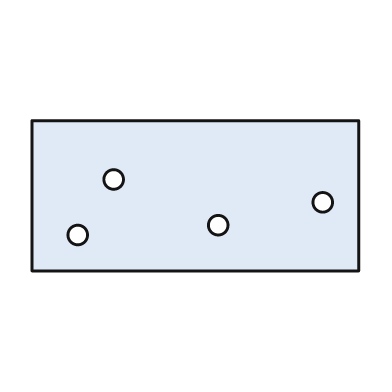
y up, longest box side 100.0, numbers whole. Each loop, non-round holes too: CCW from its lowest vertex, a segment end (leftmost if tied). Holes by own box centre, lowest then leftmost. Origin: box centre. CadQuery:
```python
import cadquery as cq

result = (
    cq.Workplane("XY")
    .moveTo(-50.0, -23.0)
    .lineTo(50.0, -23.0)
    .lineTo(50.0, 23.0)
    .lineTo(-50.0, 23.0)
    .close()
    .moveTo(-36.0, -12.0)
    .circle(3.0)
    .moveTo(7.0, -9.0)
    .circle(3.0)
    .moveTo(39.0, -2.0)
    .circle(3.0)
    .moveTo(-25.0, 5.0)
    .circle(3.0)
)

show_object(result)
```